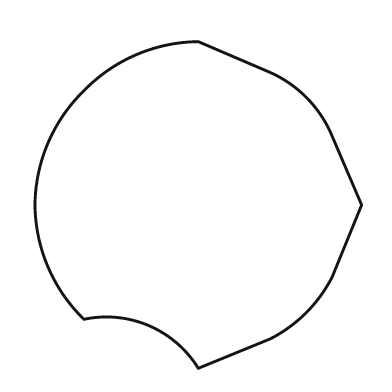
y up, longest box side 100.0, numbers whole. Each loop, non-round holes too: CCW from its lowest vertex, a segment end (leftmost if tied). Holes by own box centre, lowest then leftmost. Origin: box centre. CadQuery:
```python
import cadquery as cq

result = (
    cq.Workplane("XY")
    .moveTo(0.0, -50.0)
    .lineTo(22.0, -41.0)
    .threePointArc((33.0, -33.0), (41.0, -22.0))
    .lineTo(50.0, 0.0)
    .lineTo(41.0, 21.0)
    .threePointArc((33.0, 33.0), (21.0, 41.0))
    .lineTo(0.0, 50.0)
    .threePointArc((-19.0, 46.0), (-35.0, 35.0))
    .threePointArc((-46.0, 19.0), (-50.0, 0.0))
    .threePointArc((-46.0, -19.0), (-35.0, -35.0))
    .threePointArc((-15.0, -37.0), (0.0, -50.0))
    .close()
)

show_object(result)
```